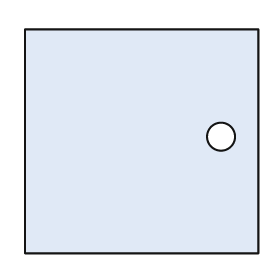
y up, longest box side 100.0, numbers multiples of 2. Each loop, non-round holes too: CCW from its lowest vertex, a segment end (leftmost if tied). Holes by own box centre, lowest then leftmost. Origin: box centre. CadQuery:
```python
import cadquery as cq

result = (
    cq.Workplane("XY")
    .moveTo(-50.0, -48.0)
    .lineTo(50.0, -48.0)
    .lineTo(50.0, 48.0)
    .lineTo(-50.0, 48.0)
    .close()
    .moveTo(34.0, 2.0)
    .circle(6.0)
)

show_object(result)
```